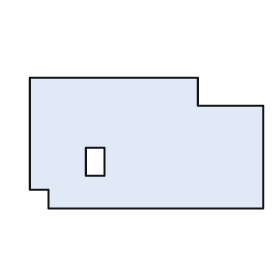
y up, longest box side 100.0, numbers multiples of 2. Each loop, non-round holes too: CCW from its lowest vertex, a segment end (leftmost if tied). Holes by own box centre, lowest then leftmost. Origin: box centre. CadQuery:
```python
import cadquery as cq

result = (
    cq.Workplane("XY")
    .moveTo(-42.0, -28.0)
    .lineTo(50.0, -28.0)
    .lineTo(50.0, 16.0)
    .lineTo(22.0, 16.0)
    .lineTo(22.0, 28.0)
    .lineTo(-50.0, 28.0)
    .lineTo(-50.0, -20.0)
    .lineTo(-42.0, -20.0)
    .close()
    .moveTo(-26.0, -14.0)
    .lineTo(-18.0, -14.0)
    .lineTo(-18.0, -2.0)
    .lineTo(-26.0, -2.0)
    .close()
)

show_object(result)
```